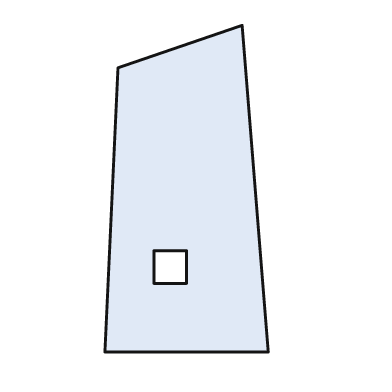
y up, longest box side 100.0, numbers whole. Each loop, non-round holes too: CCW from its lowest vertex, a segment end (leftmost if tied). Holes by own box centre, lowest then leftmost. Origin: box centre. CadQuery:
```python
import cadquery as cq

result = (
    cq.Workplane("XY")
    .moveTo(-25.0, -50.0)
    .lineTo(25.0, -50.0)
    .lineTo(17.0, 50.0)
    .lineTo(-21.0, 37.0)
    .close()
    .moveTo(-10.0, -29.0)
    .lineTo(0.0, -29.0)
    .lineTo(0.0, -19.0)
    .lineTo(-10.0, -19.0)
    .close()
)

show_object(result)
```